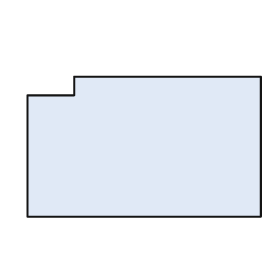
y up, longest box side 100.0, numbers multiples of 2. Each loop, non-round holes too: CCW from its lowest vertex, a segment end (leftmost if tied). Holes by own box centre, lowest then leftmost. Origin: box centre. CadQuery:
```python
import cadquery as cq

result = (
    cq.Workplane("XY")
    .moveTo(-50.0, -30.0)
    .lineTo(50.0, -30.0)
    .lineTo(50.0, 30.0)
    .lineTo(-30.0, 30.0)
    .lineTo(-30.0, 22.0)
    .lineTo(-50.0, 22.0)
    .close()
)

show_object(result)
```